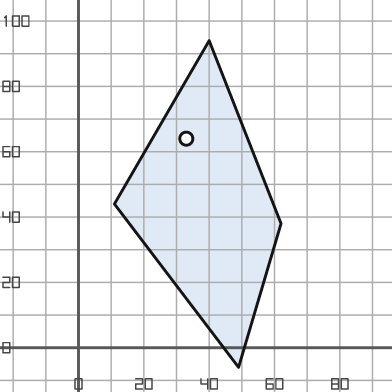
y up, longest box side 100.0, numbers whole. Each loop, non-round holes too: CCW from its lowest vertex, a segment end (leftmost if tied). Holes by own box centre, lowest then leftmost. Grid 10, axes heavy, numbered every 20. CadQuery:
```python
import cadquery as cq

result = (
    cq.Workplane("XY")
    .moveTo(49.0, -6.0)
    .lineTo(62.0, 38.0)
    .lineTo(40.0, 94.0)
    .lineTo(11.0, 44.0)
    .close()
    .moveTo(33.0, 64.0)
    .circle(2.0)
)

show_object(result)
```